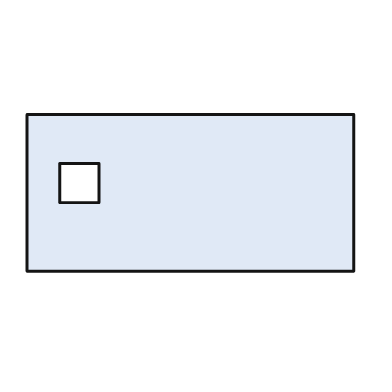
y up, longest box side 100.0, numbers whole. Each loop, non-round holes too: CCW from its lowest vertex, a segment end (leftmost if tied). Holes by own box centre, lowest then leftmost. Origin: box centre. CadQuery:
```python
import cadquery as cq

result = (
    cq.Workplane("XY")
    .moveTo(-50.0, -24.0)
    .lineTo(50.0, -24.0)
    .lineTo(50.0, 24.0)
    .lineTo(-50.0, 24.0)
    .close()
    .moveTo(-40.0, -3.0)
    .lineTo(-28.0, -3.0)
    .lineTo(-28.0, 9.0)
    .lineTo(-40.0, 9.0)
    .close()
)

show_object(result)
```